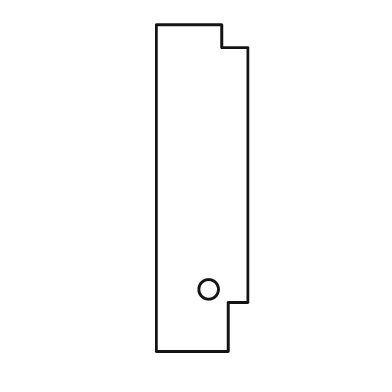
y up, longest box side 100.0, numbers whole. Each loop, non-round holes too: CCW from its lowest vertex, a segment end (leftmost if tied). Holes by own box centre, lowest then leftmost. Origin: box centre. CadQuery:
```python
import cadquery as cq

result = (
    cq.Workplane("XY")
    .moveTo(-14.0, -50.0)
    .lineTo(8.0, -50.0)
    .lineTo(8.0, -35.0)
    .lineTo(14.0, -35.0)
    .lineTo(14.0, 43.0)
    .lineTo(6.0, 43.0)
    .lineTo(6.0, 50.0)
    .lineTo(-14.0, 50.0)
    .close()
    .moveTo(2.0, -31.0)
    .circle(3.0)
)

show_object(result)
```